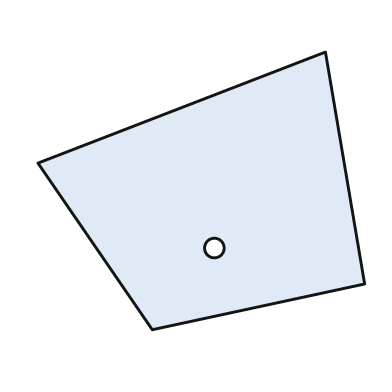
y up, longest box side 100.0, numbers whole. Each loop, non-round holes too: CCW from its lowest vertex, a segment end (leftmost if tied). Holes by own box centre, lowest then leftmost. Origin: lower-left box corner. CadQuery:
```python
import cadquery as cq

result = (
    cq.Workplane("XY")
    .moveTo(35.0, 0.0)
    .lineTo(100.0, 14.0)
    .lineTo(88.0, 85.0)
    .lineTo(0.0, 51.0)
    .close()
    .moveTo(54.0, 25.0)
    .circle(3.0)
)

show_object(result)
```